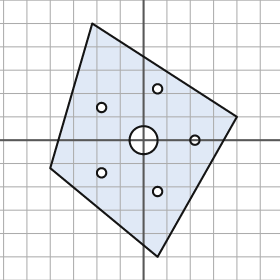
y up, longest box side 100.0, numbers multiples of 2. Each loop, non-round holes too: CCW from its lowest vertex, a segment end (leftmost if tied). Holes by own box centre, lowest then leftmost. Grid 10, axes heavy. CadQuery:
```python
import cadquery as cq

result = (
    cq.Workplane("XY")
    .moveTo(6.0, -50.0)
    .lineTo(40.0, 10.0)
    .lineTo(-22.0, 50.0)
    .lineTo(-40.0, -12.0)
    .close()
    .moveTo(6.0, -22.0)
    .circle(2.0)
    .moveTo(-18.0, -14.0)
    .circle(2.0)
    .moveTo(0.0, 0.0)
    .circle(6.0)
    .moveTo(22.0, 0.0)
    .circle(2.0)
    .moveTo(-18.0, 14.0)
    .circle(2.0)
    .moveTo(6.0, 22.0)
    .circle(2.0)
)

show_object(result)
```